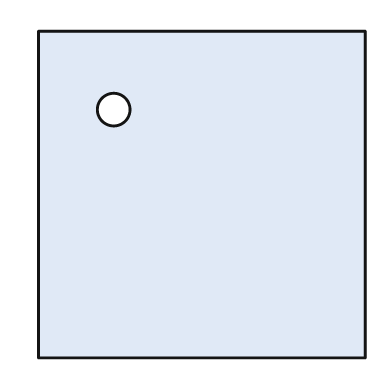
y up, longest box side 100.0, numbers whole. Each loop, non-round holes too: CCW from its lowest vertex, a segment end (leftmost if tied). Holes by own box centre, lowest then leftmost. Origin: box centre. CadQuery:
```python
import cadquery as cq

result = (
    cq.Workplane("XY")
    .moveTo(-50.0, -50.0)
    .lineTo(50.0, -50.0)
    .lineTo(50.0, 50.0)
    .lineTo(-50.0, 50.0)
    .close()
    .moveTo(-27.0, 26.0)
    .circle(5.0)
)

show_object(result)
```